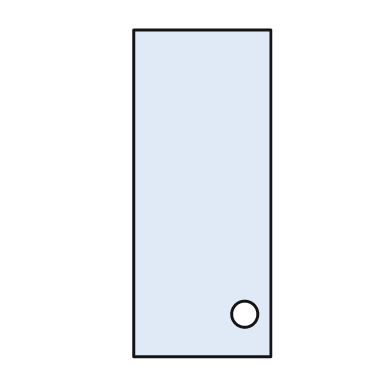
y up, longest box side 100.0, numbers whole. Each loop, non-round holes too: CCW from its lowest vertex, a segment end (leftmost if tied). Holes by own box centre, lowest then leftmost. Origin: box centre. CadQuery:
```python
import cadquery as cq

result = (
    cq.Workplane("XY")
    .moveTo(-21.0, -50.0)
    .lineTo(21.0, -50.0)
    .lineTo(21.0, 50.0)
    .lineTo(-21.0, 50.0)
    .close()
    .moveTo(13.0, -37.0)
    .circle(4.0)
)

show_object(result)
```